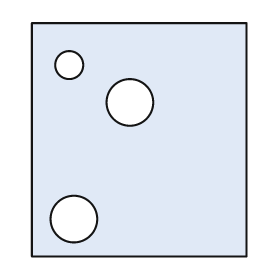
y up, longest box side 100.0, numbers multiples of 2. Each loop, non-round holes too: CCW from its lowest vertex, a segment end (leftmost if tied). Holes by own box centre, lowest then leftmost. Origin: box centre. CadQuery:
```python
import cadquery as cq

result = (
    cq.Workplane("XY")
    .moveTo(-46.0, -50.0)
    .lineTo(46.0, -50.0)
    .lineTo(46.0, 50.0)
    .lineTo(-46.0, 50.0)
    .close()
    .moveTo(-28.0, -34.0)
    .circle(10.0)
    .moveTo(-4.0, 16.0)
    .circle(10.0)
    .moveTo(-30.0, 32.0)
    .circle(6.0)
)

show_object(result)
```